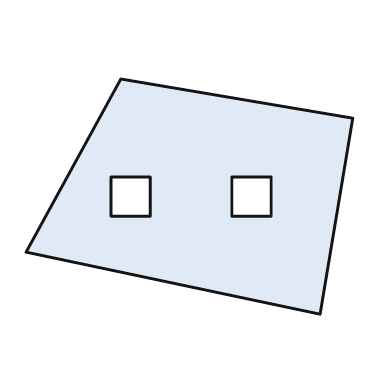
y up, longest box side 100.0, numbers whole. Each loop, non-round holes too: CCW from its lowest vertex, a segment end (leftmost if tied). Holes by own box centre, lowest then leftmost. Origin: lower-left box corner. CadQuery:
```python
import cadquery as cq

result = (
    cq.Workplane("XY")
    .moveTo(90.0, 0.0)
    .lineTo(100.0, 60.0)
    .lineTo(29.0, 72.0)
    .lineTo(0.0, 19.0)
    .close()
    .moveTo(26.0, 30.0)
    .lineTo(38.0, 30.0)
    .lineTo(38.0, 42.0)
    .lineTo(26.0, 42.0)
    .close()
    .moveTo(63.0, 30.0)
    .lineTo(75.0, 30.0)
    .lineTo(75.0, 42.0)
    .lineTo(63.0, 42.0)
    .close()
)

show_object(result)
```